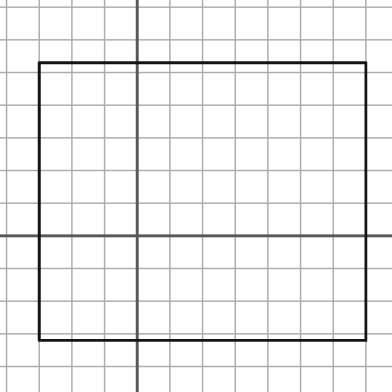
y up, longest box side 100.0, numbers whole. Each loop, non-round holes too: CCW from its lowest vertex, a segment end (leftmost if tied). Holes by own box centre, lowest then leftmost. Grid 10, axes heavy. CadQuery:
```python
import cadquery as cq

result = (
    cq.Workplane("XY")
    .moveTo(-30.0, -32.0)
    .lineTo(70.0, -32.0)
    .lineTo(70.0, 53.0)
    .lineTo(-30.0, 53.0)
    .close()
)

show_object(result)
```